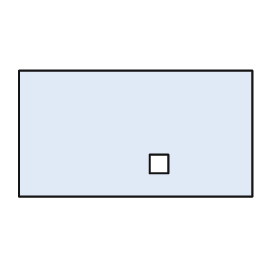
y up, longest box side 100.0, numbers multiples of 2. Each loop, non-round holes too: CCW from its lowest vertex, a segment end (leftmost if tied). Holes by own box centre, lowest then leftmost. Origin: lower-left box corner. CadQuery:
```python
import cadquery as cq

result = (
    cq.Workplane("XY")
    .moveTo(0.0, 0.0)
    .lineTo(100.0, 0.0)
    .lineTo(100.0, 54.0)
    .lineTo(0.0, 54.0)
    .close()
    .moveTo(56.0, 10.0)
    .lineTo(64.0, 10.0)
    .lineTo(64.0, 18.0)
    .lineTo(56.0, 18.0)
    .close()
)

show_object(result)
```